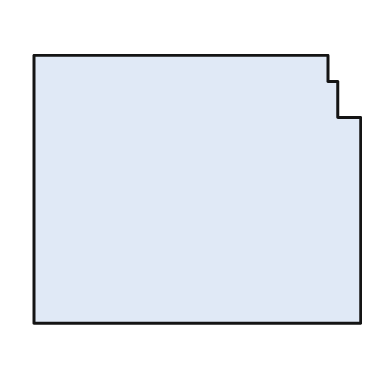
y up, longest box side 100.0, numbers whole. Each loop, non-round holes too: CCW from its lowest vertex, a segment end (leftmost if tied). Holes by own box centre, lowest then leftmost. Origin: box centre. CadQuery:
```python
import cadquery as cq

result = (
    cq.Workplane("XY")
    .moveTo(-50.0, -41.0)
    .lineTo(50.0, -41.0)
    .lineTo(50.0, 22.0)
    .lineTo(43.0, 22.0)
    .lineTo(43.0, 33.0)
    .lineTo(40.0, 33.0)
    .lineTo(40.0, 41.0)
    .lineTo(-50.0, 41.0)
    .close()
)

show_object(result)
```